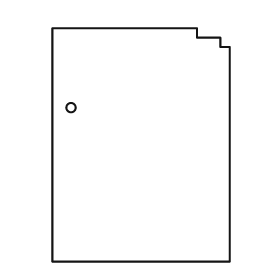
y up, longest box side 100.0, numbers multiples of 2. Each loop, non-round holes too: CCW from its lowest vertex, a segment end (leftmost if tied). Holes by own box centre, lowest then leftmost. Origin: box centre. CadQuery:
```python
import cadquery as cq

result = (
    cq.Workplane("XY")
    .moveTo(-38.0, -50.0)
    .lineTo(38.0, -50.0)
    .lineTo(38.0, 42.0)
    .lineTo(34.0, 42.0)
    .lineTo(34.0, 46.0)
    .lineTo(24.0, 46.0)
    .lineTo(24.0, 50.0)
    .lineTo(-38.0, 50.0)
    .close()
    .moveTo(-30.0, 16.0)
    .circle(2.0)
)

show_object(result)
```